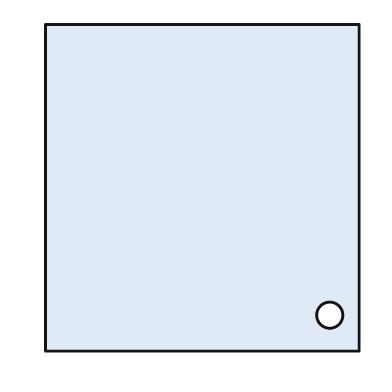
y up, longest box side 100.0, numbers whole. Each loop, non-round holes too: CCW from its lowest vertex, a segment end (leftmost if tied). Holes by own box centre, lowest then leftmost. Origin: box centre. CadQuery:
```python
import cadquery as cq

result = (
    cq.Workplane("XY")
    .moveTo(-48.0, -50.0)
    .lineTo(48.0, -50.0)
    .lineTo(48.0, 50.0)
    .lineTo(-48.0, 50.0)
    .close()
    .moveTo(39.0, -39.0)
    .circle(4.0)
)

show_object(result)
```